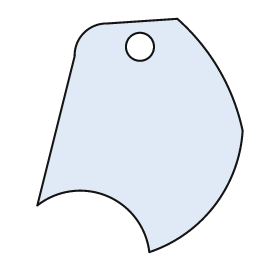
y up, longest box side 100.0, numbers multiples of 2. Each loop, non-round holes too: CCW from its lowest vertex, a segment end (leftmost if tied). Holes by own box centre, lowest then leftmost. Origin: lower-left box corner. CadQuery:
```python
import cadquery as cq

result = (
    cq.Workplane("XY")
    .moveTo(48.0, 0.0)
    .threePointArc((76.0, 20.0), (88.0, 52.0))
    .threePointArc((78.0, 78.0), (60.0, 100.0))
    .lineTo(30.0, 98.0)
    .threePointArc((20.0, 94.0), (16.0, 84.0))
    .lineTo(0.0, 20.0)
    .threePointArc((30.0, 24.0), (48.0, 0.0))
    .close()
    .moveTo(44.0, 88.0)
    .circle(6.0)
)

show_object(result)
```